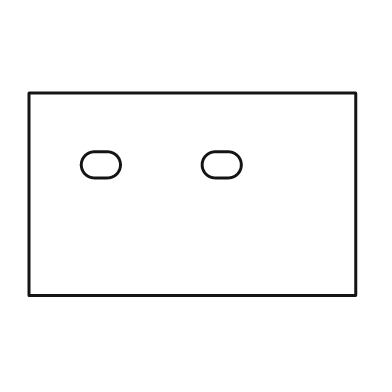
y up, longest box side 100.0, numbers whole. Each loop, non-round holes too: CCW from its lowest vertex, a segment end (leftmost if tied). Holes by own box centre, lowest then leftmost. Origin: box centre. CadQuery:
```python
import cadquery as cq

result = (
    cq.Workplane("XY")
    .moveTo(-50.0, -31.0)
    .lineTo(50.0, -31.0)
    .lineTo(50.0, 31.0)
    .lineTo(-50.0, 31.0)
    .close()
    .moveTo(-30.0, 5.0)
    .lineTo(-26.0, 5.0)
    .threePointArc((-22.0, 9.0), (-26.0, 13.0))
    .lineTo(-30.0, 13.0)
    .threePointArc((-34.0, 9.0), (-30.0, 5.0))
    .close()
    .moveTo(7.0, 5.0)
    .lineTo(11.0, 5.0)
    .threePointArc((15.0, 9.0), (11.0, 13.0))
    .lineTo(7.0, 13.0)
    .threePointArc((3.0, 9.0), (7.0, 5.0))
    .close()
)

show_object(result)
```